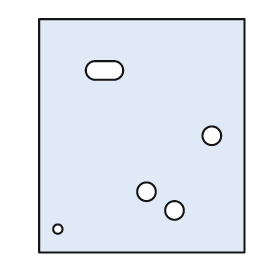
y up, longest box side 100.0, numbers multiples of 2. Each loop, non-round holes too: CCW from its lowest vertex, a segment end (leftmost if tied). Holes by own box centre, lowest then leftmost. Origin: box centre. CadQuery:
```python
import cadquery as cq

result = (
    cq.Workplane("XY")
    .moveTo(-44.0, -50.0)
    .lineTo(44.0, -50.0)
    .lineTo(44.0, 50.0)
    .lineTo(-44.0, 50.0)
    .close()
    .moveTo(-36.0, -40.0)
    .circle(2.0)
    .moveTo(14.0, -32.0)
    .circle(4.0)
    .moveTo(2.0, -24.0)
    .circle(4.0)
    .moveTo(30.0, 0.0)
    .circle(4.0)
    .moveTo(-20.0, 24.0)
    .lineTo(-12.0, 24.0)
    .threePointArc((-8.0, 28.0), (-12.0, 32.0))
    .lineTo(-20.0, 32.0)
    .threePointArc((-24.0, 28.0), (-20.0, 24.0))
    .close()
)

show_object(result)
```